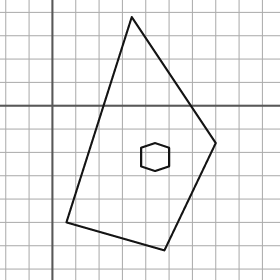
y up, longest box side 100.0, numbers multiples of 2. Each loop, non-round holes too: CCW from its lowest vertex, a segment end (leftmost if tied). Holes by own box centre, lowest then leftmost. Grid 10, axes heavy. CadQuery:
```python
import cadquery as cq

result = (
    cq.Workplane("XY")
    .moveTo(48.0, -62.0)
    .lineTo(70.0, -16.0)
    .lineTo(34.0, 38.0)
    .lineTo(6.0, -50.0)
    .close()
    .moveTo(44.0, -28.0)
    .lineTo(50.0, -26.0)
    .lineTo(50.0, -18.0)
    .lineTo(44.0, -16.0)
    .lineTo(38.0, -18.0)
    .lineTo(38.0, -26.0)
    .close()
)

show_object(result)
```